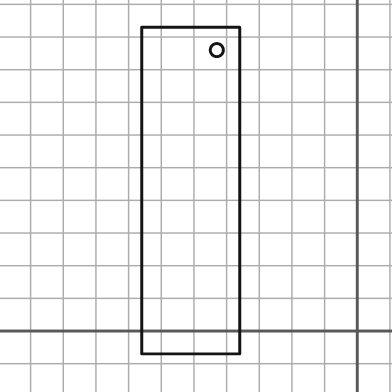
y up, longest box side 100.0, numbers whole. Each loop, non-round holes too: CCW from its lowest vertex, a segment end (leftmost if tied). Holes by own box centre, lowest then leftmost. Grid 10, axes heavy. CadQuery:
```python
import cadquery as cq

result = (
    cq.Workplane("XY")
    .moveTo(-66.0, -7.0)
    .lineTo(-36.0, -7.0)
    .lineTo(-36.0, 93.0)
    .lineTo(-66.0, 93.0)
    .close()
    .moveTo(-43.0, 86.0)
    .circle(2.0)
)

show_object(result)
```